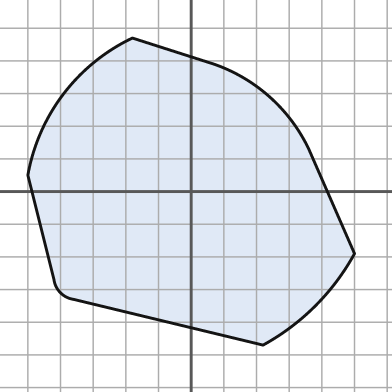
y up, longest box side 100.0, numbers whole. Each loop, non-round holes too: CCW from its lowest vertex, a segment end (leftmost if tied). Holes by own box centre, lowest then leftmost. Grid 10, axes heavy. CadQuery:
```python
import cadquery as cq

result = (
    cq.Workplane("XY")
    .moveTo(22.0, -47.0)
    .threePointArc((38.0, -35.0), (50.0, -19.0))
    .lineTo(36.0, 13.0)
    .threePointArc((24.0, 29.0), (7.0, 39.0))
    .lineTo(-18.0, 47.0)
    .threePointArc((-39.0, 30.0), (-50.0, 5.0))
    .lineTo(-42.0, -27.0)
    .threePointArc((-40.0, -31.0), (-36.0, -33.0))
    .close()
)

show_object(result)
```